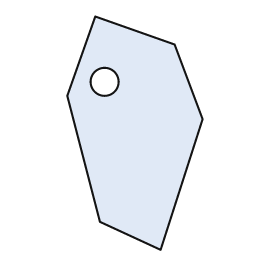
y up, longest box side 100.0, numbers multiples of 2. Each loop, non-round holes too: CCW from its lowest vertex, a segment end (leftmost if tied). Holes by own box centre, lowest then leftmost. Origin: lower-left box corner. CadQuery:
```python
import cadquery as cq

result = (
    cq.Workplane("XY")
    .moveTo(40.0, 0.0)
    .lineTo(58.0, 56.0)
    .lineTo(46.0, 88.0)
    .lineTo(12.0, 100.0)
    .lineTo(0.0, 66.0)
    .lineTo(14.0, 12.0)
    .close()
    .moveTo(16.0, 72.0)
    .circle(6.0)
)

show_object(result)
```